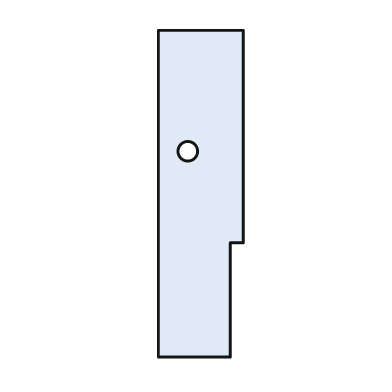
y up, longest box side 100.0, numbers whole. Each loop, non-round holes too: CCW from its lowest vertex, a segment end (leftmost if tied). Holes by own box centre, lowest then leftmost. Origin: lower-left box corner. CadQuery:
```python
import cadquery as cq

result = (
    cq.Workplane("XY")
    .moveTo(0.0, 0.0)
    .lineTo(22.0, 0.0)
    .lineTo(22.0, 35.0)
    .lineTo(26.0, 35.0)
    .lineTo(26.0, 100.0)
    .lineTo(0.0, 100.0)
    .close()
    .moveTo(9.0, 63.0)
    .circle(3.0)
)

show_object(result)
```